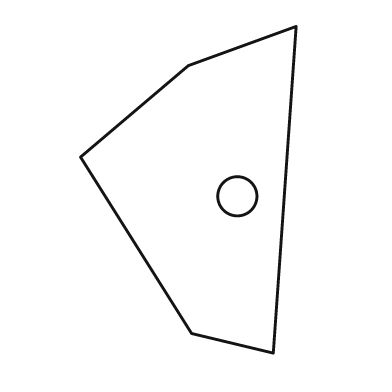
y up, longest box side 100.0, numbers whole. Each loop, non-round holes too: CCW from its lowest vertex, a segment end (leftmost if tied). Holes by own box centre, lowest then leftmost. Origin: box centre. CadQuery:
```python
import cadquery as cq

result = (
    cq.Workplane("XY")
    .moveTo(26.0, -50.0)
    .lineTo(33.0, 50.0)
    .lineTo(0.0, 38.0)
    .lineTo(-33.0, 10.0)
    .lineTo(1.0, -44.0)
    .close()
    .moveTo(15.0, -2.0)
    .circle(6.0)
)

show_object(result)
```